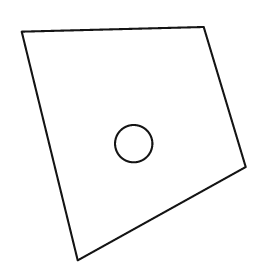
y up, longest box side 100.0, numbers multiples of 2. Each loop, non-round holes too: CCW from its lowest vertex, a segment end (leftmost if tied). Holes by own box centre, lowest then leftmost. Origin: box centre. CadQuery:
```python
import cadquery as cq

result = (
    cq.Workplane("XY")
    .moveTo(-24.0, -50.0)
    .lineTo(48.0, -10.0)
    .lineTo(30.0, 50.0)
    .lineTo(-48.0, 48.0)
    .close()
    .moveTo(0.0, 0.0)
    .circle(8.0)
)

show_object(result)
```